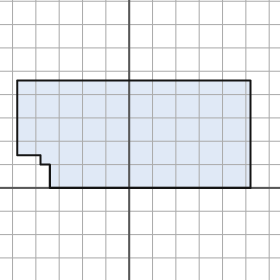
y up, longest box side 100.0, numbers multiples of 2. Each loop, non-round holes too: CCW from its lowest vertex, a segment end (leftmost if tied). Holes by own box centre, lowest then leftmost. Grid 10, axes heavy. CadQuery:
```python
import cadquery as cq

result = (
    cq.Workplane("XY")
    .moveTo(-34.0, 0.0)
    .lineTo(52.0, 0.0)
    .lineTo(52.0, 46.0)
    .lineTo(-48.0, 46.0)
    .lineTo(-48.0, 14.0)
    .lineTo(-38.0, 14.0)
    .lineTo(-38.0, 10.0)
    .lineTo(-34.0, 10.0)
    .close()
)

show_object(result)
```